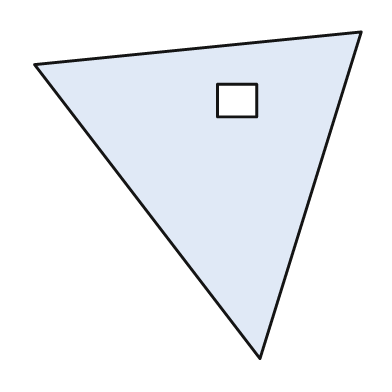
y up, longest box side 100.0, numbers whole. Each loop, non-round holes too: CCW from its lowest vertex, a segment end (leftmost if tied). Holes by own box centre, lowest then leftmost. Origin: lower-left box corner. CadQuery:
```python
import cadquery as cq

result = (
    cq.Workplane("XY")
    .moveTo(69.0, 0.0)
    .lineTo(100.0, 100.0)
    .lineTo(0.0, 90.0)
    .close()
    .moveTo(56.0, 74.0)
    .lineTo(68.0, 74.0)
    .lineTo(68.0, 84.0)
    .lineTo(56.0, 84.0)
    .close()
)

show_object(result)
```